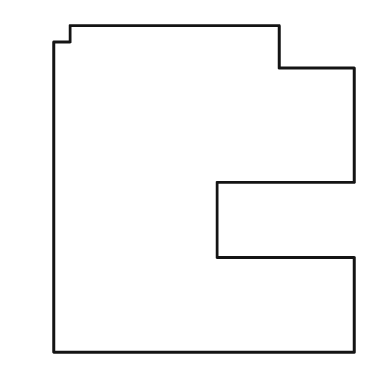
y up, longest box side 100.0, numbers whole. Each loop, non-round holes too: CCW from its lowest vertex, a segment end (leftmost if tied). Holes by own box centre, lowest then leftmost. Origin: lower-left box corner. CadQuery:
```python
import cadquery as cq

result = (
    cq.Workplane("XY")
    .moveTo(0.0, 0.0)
    .lineTo(92.0, 0.0)
    .lineTo(92.0, 29.0)
    .lineTo(50.0, 29.0)
    .lineTo(50.0, 52.0)
    .lineTo(92.0, 52.0)
    .lineTo(92.0, 87.0)
    .lineTo(69.0, 87.0)
    .lineTo(69.0, 100.0)
    .lineTo(5.0, 100.0)
    .lineTo(5.0, 95.0)
    .lineTo(0.0, 95.0)
    .close()
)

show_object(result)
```